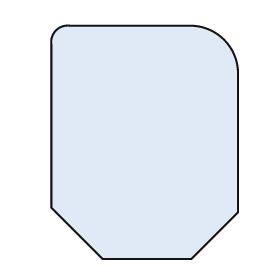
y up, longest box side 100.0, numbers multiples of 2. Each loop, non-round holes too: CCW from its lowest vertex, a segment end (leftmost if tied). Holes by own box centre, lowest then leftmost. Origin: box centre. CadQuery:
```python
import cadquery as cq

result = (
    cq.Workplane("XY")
    .moveTo(-18.0, -50.0)
    .lineTo(20.0, -50.0)
    .lineTo(40.0, -30.0)
    .lineTo(40.0, 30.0)
    .threePointArc((34.0, 44.0), (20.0, 50.0))
    .lineTo(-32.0, 50.0)
    .threePointArc((-38.0, 48.0), (-40.0, 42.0))
    .lineTo(-40.0, -28.0)
    .close()
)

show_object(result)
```